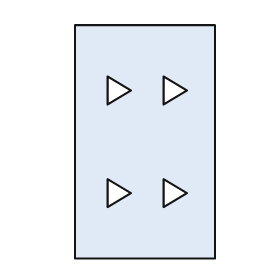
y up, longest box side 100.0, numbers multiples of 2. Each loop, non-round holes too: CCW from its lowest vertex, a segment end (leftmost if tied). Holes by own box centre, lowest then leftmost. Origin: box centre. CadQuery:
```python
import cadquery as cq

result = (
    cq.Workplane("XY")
    .moveTo(-30.0, -50.0)
    .lineTo(30.0, -50.0)
    .lineTo(30.0, 50.0)
    .lineTo(-30.0, 50.0)
    .close()
    .moveTo(-16.0, -28.0)
    .lineTo(-6.0, -22.0)
    .lineTo(-16.0, -16.0)
    .close()
    .moveTo(8.0, -28.0)
    .lineTo(18.0, -22.0)
    .lineTo(8.0, -16.0)
    .close()
    .moveTo(-16.0, 16.0)
    .lineTo(-6.0, 22.0)
    .lineTo(-16.0, 28.0)
    .close()
    .moveTo(8.0, 16.0)
    .lineTo(18.0, 22.0)
    .lineTo(8.0, 28.0)
    .close()
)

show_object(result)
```